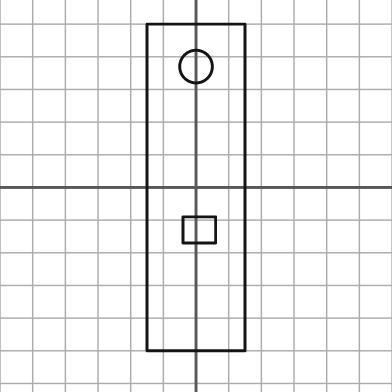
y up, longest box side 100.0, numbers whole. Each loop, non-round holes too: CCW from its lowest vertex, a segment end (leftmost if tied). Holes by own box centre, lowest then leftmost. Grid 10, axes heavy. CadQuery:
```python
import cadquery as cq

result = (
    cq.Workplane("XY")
    .moveTo(-15.0, -50.0)
    .lineTo(15.0, -50.0)
    .lineTo(15.0, 50.0)
    .lineTo(-15.0, 50.0)
    .close()
    .moveTo(-4.0, -17.0)
    .lineTo(6.0, -17.0)
    .lineTo(6.0, -9.0)
    .lineTo(-4.0, -9.0)
    .close()
    .moveTo(0.0, 37.0)
    .circle(5.0)
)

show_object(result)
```